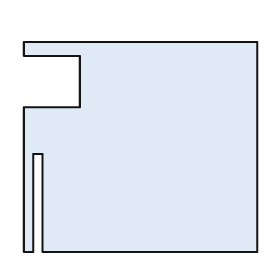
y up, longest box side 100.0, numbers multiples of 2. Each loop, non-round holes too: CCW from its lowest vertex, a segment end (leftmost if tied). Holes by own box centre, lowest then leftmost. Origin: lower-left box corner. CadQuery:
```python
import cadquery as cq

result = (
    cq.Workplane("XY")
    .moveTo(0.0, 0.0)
    .lineTo(4.0, 0.0)
    .lineTo(4.0, 42.0)
    .lineTo(8.0, 42.0)
    .lineTo(8.0, 0.0)
    .lineTo(100.0, 0.0)
    .lineTo(100.0, 90.0)
    .lineTo(0.0, 90.0)
    .lineTo(0.0, 84.0)
    .lineTo(24.0, 84.0)
    .lineTo(24.0, 62.0)
    .lineTo(0.0, 62.0)
    .close()
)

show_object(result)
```